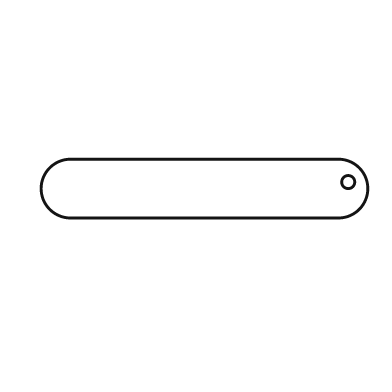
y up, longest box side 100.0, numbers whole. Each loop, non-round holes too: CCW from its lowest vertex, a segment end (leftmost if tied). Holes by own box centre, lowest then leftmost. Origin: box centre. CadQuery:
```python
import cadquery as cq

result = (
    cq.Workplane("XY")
    .moveTo(-41.0, -9.0)
    .lineTo(41.0, -9.0)
    .threePointArc((50.0, 0.0), (41.0, 9.0))
    .lineTo(-41.0, 9.0)
    .threePointArc((-50.0, 0.0), (-41.0, -9.0))
    .close()
    .moveTo(44.0, 2.0)
    .circle(2.0)
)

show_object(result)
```